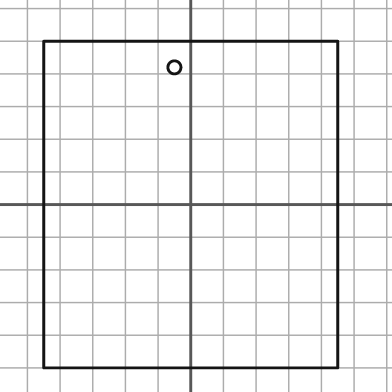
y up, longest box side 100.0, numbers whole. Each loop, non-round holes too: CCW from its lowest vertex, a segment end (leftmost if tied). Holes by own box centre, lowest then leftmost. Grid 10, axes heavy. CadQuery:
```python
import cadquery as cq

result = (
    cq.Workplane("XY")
    .moveTo(-45.0, -50.0)
    .lineTo(45.0, -50.0)
    .lineTo(45.0, 50.0)
    .lineTo(-45.0, 50.0)
    .close()
    .moveTo(-5.0, 42.0)
    .circle(2.0)
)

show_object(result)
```